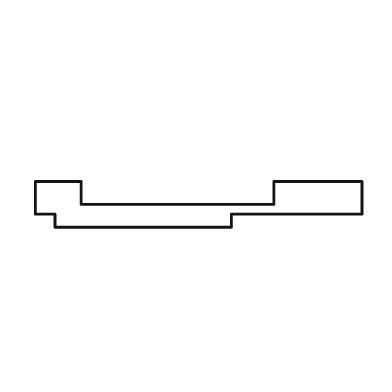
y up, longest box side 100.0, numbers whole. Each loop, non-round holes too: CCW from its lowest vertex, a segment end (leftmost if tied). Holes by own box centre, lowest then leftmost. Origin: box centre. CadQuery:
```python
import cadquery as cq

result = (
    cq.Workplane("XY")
    .moveTo(-44.0, -7.0)
    .lineTo(10.0, -7.0)
    .lineTo(10.0, -3.0)
    .lineTo(50.0, -3.0)
    .lineTo(50.0, 7.0)
    .lineTo(23.0, 7.0)
    .lineTo(23.0, 0.0)
    .lineTo(-36.0, 0.0)
    .lineTo(-36.0, 7.0)
    .lineTo(-50.0, 7.0)
    .lineTo(-50.0, -3.0)
    .lineTo(-44.0, -3.0)
    .close()
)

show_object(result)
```